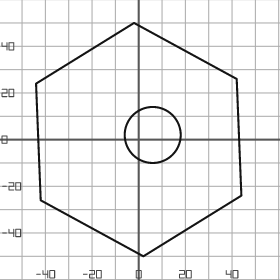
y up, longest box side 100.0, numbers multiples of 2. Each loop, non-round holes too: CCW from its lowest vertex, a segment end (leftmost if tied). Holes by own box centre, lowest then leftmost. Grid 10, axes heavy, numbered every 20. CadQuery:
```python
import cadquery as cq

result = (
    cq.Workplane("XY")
    .moveTo(2.0, -50.0)
    .lineTo(44.0, -24.0)
    .lineTo(42.0, 26.0)
    .lineTo(-2.0, 50.0)
    .lineTo(-44.0, 24.0)
    .lineTo(-42.0, -26.0)
    .close()
    .moveTo(6.0, 2.0)
    .circle(12.0)
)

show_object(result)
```